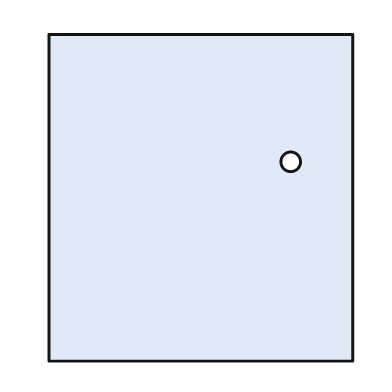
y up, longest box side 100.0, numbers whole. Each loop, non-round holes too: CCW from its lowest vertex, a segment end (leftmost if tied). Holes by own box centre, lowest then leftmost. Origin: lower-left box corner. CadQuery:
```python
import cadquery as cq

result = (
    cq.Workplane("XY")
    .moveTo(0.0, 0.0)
    .lineTo(93.0, 0.0)
    .lineTo(93.0, 100.0)
    .lineTo(0.0, 100.0)
    .close()
    .moveTo(74.0, 61.0)
    .circle(3.0)
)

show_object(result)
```